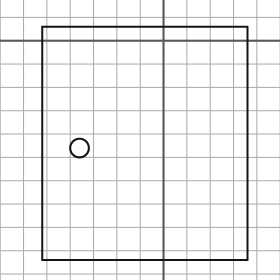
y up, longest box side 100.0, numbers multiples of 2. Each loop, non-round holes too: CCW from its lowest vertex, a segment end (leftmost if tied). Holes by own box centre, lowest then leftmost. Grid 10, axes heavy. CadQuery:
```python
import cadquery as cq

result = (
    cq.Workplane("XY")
    .moveTo(-52.0, -94.0)
    .lineTo(36.0, -94.0)
    .lineTo(36.0, 6.0)
    .lineTo(-52.0, 6.0)
    .close()
    .moveTo(-36.0, -46.0)
    .circle(4.0)
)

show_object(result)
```